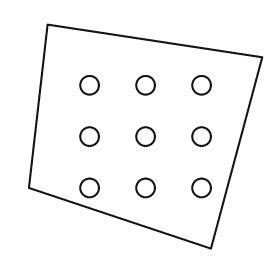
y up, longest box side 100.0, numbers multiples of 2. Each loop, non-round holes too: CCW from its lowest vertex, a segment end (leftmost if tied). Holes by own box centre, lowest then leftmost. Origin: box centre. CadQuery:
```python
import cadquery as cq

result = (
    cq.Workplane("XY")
    .moveTo(28.0, -48.0)
    .lineTo(50.0, 34.0)
    .lineTo(-42.0, 48.0)
    .lineTo(-50.0, -22.0)
    .close()
    .moveTo(-24.0, -22.0)
    .circle(4.0)
    .moveTo(0.0, -22.0)
    .circle(4.0)
    .moveTo(24.0, -22.0)
    .circle(4.0)
    .moveTo(-24.0, 0.0)
    .circle(4.0)
    .moveTo(0.0, 0.0)
    .circle(4.0)
    .moveTo(24.0, 0.0)
    .circle(4.0)
    .moveTo(-24.0, 22.0)
    .circle(4.0)
    .moveTo(0.0, 22.0)
    .circle(4.0)
    .moveTo(24.0, 22.0)
    .circle(4.0)
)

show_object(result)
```